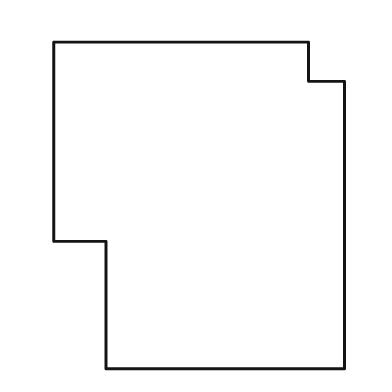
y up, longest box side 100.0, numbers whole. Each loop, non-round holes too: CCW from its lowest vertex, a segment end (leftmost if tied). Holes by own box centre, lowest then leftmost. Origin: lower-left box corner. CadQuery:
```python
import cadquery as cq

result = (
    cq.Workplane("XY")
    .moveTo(16.0, 0.0)
    .lineTo(89.0, 0.0)
    .lineTo(89.0, 88.0)
    .lineTo(78.0, 88.0)
    .lineTo(78.0, 100.0)
    .lineTo(0.0, 100.0)
    .lineTo(0.0, 39.0)
    .lineTo(16.0, 39.0)
    .close()
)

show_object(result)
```